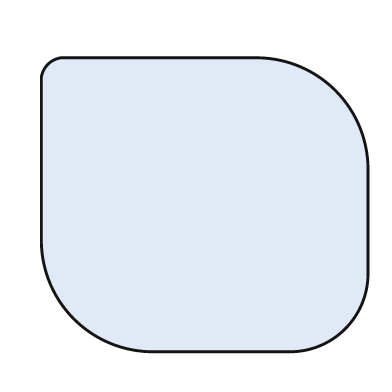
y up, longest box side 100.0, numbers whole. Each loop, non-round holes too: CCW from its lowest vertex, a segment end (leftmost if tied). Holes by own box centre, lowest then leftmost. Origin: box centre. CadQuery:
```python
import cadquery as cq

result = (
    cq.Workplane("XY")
    .moveTo(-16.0, -45.0)
    .lineTo(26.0, -45.0)
    .threePointArc((43.0, -38.0), (50.0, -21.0))
    .lineTo(50.0, 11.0)
    .threePointArc((40.0, 35.0), (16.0, 45.0))
    .lineTo(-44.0, 45.0)
    .threePointArc((-48.0, 43.0), (-50.0, 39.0))
    .lineTo(-50.0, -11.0)
    .threePointArc((-40.0, -35.0), (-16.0, -45.0))
    .close()
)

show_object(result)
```